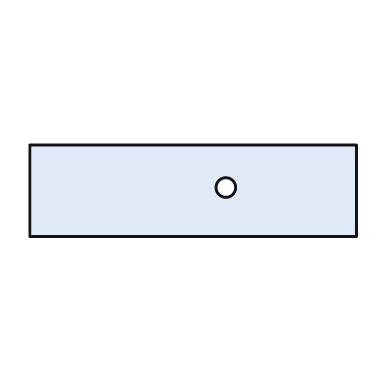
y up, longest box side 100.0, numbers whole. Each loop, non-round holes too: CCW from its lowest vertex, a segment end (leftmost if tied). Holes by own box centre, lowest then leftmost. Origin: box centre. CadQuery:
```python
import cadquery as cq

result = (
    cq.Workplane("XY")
    .moveTo(-50.0, -14.0)
    .lineTo(50.0, -14.0)
    .lineTo(50.0, 14.0)
    .lineTo(-50.0, 14.0)
    .close()
    .moveTo(10.0, 1.0)
    .circle(3.0)
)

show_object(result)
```